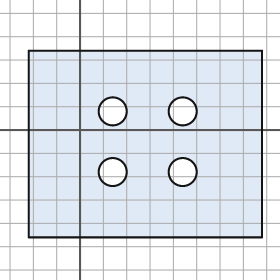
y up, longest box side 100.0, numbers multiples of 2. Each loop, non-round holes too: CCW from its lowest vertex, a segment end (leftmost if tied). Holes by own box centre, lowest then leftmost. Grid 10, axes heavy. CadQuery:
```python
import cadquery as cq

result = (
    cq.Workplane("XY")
    .moveTo(-22.0, -46.0)
    .lineTo(78.0, -46.0)
    .lineTo(78.0, 34.0)
    .lineTo(-22.0, 34.0)
    .close()
    .moveTo(14.0, -18.0)
    .circle(6.0)
    .moveTo(44.0, -18.0)
    .circle(6.0)
    .moveTo(14.0, 8.0)
    .circle(6.0)
    .moveTo(44.0, 8.0)
    .circle(6.0)
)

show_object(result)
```